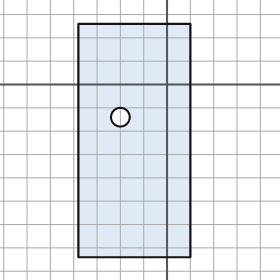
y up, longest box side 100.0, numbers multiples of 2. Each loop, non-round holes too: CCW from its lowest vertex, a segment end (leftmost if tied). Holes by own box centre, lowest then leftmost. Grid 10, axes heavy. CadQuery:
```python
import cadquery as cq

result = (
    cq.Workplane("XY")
    .moveTo(-38.0, -74.0)
    .lineTo(10.0, -74.0)
    .lineTo(10.0, 26.0)
    .lineTo(-38.0, 26.0)
    .close()
    .moveTo(-20.0, -14.0)
    .circle(4.0)
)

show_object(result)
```